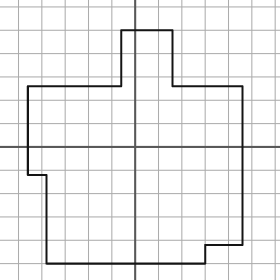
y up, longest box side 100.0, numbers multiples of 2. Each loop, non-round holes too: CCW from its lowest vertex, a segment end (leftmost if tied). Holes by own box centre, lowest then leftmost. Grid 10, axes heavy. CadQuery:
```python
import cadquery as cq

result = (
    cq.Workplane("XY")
    .moveTo(-38.0, -50.0)
    .lineTo(30.0, -50.0)
    .lineTo(30.0, -42.0)
    .lineTo(46.0, -42.0)
    .lineTo(46.0, 26.0)
    .lineTo(16.0, 26.0)
    .lineTo(16.0, 50.0)
    .lineTo(-6.0, 50.0)
    .lineTo(-6.0, 26.0)
    .lineTo(-46.0, 26.0)
    .lineTo(-46.0, -12.0)
    .lineTo(-38.0, -12.0)
    .close()
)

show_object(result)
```